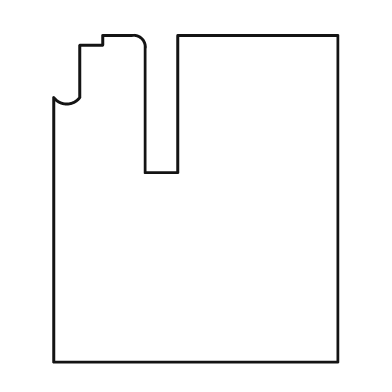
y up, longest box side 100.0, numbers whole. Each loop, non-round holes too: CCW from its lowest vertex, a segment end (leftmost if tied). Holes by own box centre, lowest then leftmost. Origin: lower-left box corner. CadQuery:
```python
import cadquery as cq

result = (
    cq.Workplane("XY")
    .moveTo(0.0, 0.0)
    .lineTo(87.0, 0.0)
    .lineTo(87.0, 100.0)
    .lineTo(38.0, 100.0)
    .lineTo(38.0, 58.0)
    .lineTo(28.0, 58.0)
    .lineTo(28.0, 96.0)
    .threePointArc((27.0, 99.0), (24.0, 100.0))
    .lineTo(15.0, 100.0)
    .lineTo(15.0, 97.0)
    .lineTo(8.0, 97.0)
    .lineTo(8.0, 81.0)
    .threePointArc((4.0, 79.0), (0.0, 81.0))
    .close()
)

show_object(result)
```